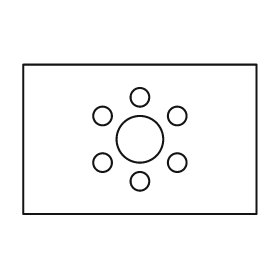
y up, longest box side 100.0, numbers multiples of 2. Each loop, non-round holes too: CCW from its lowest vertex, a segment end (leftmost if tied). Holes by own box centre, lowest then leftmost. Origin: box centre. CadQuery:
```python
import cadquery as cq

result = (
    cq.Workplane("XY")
    .moveTo(-50.0, -32.0)
    .lineTo(50.0, -32.0)
    .lineTo(50.0, 32.0)
    .lineTo(-50.0, 32.0)
    .close()
    .moveTo(0.0, -18.0)
    .circle(4.0)
    .moveTo(-16.0, -10.0)
    .circle(4.0)
    .moveTo(16.0, -10.0)
    .circle(4.0)
    .moveTo(0.0, 0.0)
    .circle(10.0)
    .moveTo(-16.0, 10.0)
    .circle(4.0)
    .moveTo(16.0, 10.0)
    .circle(4.0)
    .moveTo(0.0, 18.0)
    .circle(4.0)
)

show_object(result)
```